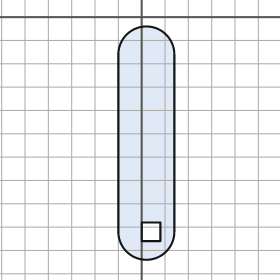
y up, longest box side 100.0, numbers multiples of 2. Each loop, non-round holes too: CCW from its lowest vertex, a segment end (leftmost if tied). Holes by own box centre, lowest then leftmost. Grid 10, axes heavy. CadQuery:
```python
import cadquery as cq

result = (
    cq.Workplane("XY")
    .moveTo(-10.0, -92.0)
    .threePointArc((2.0, -104.0), (14.0, -92.0))
    .lineTo(14.0, -16.0)
    .threePointArc((2.0, -4.0), (-10.0, -16.0))
    .close()
    .moveTo(0.0, -96.0)
    .lineTo(8.0, -96.0)
    .lineTo(8.0, -88.0)
    .lineTo(0.0, -88.0)
    .close()
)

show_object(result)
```